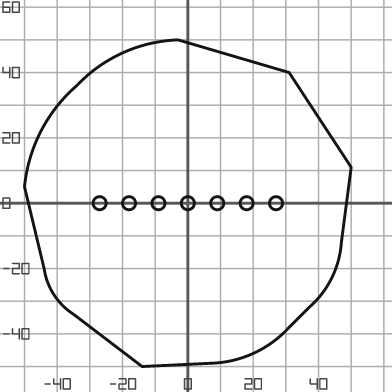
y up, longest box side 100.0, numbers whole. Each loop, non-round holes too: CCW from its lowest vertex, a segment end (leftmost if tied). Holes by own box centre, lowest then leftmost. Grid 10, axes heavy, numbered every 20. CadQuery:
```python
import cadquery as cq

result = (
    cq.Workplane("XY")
    .moveTo(-14.0, -50.0)
    .lineTo(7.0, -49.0)
    .threePointArc((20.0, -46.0), (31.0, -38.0))
    .lineTo(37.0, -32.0)
    .threePointArc((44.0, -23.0), (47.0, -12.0))
    .lineTo(50.0, 11.0)
    .lineTo(31.0, 40.0)
    .lineTo(-3.0, 50.0)
    .threePointArc((-20.0, 46.0), (-34.0, 36.0))
    .threePointArc((-45.0, 22.0), (-50.0, 5.0))
    .lineTo(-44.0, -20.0)
    .threePointArc((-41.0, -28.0), (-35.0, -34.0))
    .close()
    .moveTo(-27.0, 0.0)
    .circle(2.0)
    .moveTo(-18.0, 0.0)
    .circle(2.0)
    .moveTo(-9.0, 0.0)
    .circle(2.0)
    .moveTo(0.0, 0.0)
    .circle(2.0)
    .moveTo(9.0, 0.0)
    .circle(2.0)
    .moveTo(18.0, 0.0)
    .circle(2.0)
    .moveTo(27.0, 0.0)
    .circle(2.0)
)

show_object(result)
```